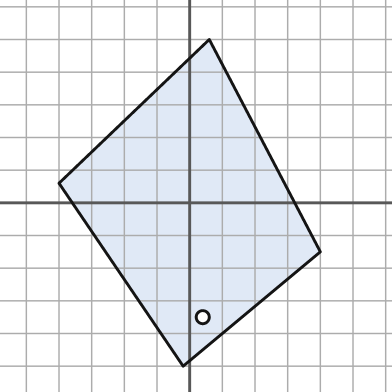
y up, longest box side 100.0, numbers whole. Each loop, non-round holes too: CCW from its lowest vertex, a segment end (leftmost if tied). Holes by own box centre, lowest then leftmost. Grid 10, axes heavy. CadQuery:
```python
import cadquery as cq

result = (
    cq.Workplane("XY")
    .moveTo(-2.0, -50.0)
    .lineTo(40.0, -15.0)
    .lineTo(6.0, 50.0)
    .lineTo(-40.0, 6.0)
    .close()
    .moveTo(4.0, -35.0)
    .circle(2.0)
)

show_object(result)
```